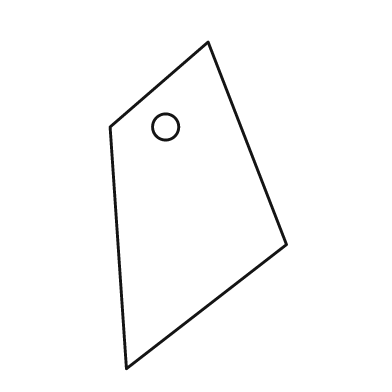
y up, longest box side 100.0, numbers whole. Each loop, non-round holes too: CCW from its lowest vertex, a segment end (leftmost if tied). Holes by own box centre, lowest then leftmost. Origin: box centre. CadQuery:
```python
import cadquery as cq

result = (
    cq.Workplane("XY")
    .moveTo(-22.0, -50.0)
    .lineTo(27.0, -12.0)
    .lineTo(3.0, 50.0)
    .lineTo(-27.0, 24.0)
    .close()
    .moveTo(-10.0, 24.0)
    .circle(4.0)
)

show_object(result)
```